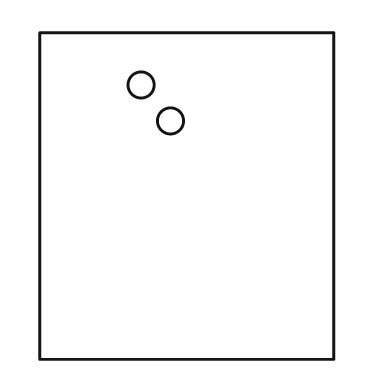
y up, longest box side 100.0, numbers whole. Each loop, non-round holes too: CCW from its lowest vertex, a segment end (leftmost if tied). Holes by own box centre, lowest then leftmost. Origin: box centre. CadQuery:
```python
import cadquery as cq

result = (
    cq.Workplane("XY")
    .moveTo(-45.0, -50.0)
    .lineTo(45.0, -50.0)
    .lineTo(45.0, 50.0)
    .lineTo(-45.0, 50.0)
    .close()
    .moveTo(-5.0, 23.0)
    .circle(4.0)
    .moveTo(-14.0, 34.0)
    .circle(4.0)
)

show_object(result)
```